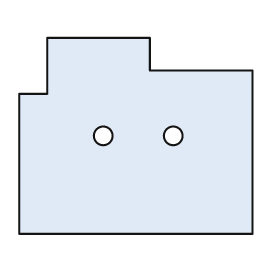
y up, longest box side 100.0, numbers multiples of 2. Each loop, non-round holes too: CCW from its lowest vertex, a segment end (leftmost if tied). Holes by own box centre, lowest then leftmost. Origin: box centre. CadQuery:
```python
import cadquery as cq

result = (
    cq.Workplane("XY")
    .moveTo(-50.0, -42.0)
    .lineTo(50.0, -42.0)
    .lineTo(50.0, 28.0)
    .lineTo(6.0, 28.0)
    .lineTo(6.0, 42.0)
    .lineTo(-38.0, 42.0)
    .lineTo(-38.0, 18.0)
    .lineTo(-50.0, 18.0)
    .close()
    .moveTo(-14.0, 0.0)
    .circle(4.0)
    .moveTo(16.0, 0.0)
    .circle(4.0)
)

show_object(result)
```